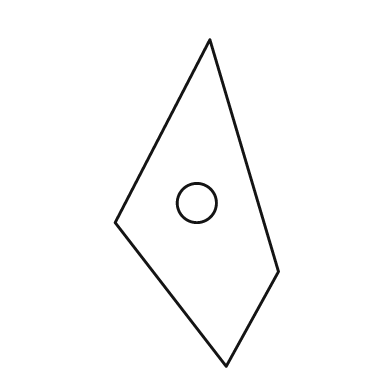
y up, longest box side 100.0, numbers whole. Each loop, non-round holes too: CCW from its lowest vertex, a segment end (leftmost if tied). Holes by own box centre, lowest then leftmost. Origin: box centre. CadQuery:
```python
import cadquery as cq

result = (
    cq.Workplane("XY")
    .moveTo(9.0, -50.0)
    .lineTo(25.0, -21.0)
    .lineTo(4.0, 50.0)
    .lineTo(-25.0, -6.0)
    .close()
    .moveTo(0.0, 0.0)
    .circle(6.0)
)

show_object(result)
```